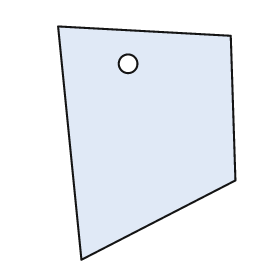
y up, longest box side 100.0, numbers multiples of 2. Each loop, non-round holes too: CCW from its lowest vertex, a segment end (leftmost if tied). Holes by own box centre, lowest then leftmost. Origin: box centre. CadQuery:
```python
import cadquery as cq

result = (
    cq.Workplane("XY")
    .moveTo(-28.0, -50.0)
    .lineTo(38.0, -16.0)
    .lineTo(36.0, 46.0)
    .lineTo(-38.0, 50.0)
    .close()
    .moveTo(-8.0, 34.0)
    .circle(4.0)
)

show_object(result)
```